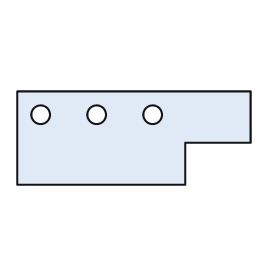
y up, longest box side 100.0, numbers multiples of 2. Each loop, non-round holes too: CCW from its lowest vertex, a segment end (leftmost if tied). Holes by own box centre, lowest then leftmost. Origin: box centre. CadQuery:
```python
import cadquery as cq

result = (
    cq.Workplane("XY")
    .moveTo(-50.0, -20.0)
    .lineTo(22.0, -20.0)
    .lineTo(22.0, -2.0)
    .lineTo(50.0, -2.0)
    .lineTo(50.0, 20.0)
    .lineTo(-50.0, 20.0)
    .close()
    .moveTo(-40.0, 10.0)
    .circle(4.0)
    .moveTo(-16.0, 10.0)
    .circle(4.0)
    .moveTo(8.0, 10.0)
    .circle(4.0)
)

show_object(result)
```